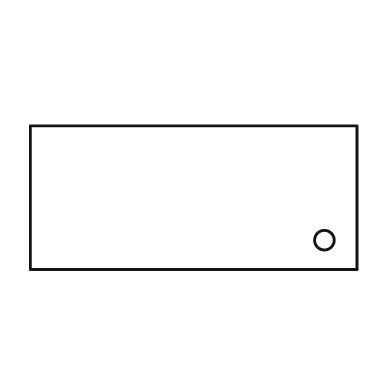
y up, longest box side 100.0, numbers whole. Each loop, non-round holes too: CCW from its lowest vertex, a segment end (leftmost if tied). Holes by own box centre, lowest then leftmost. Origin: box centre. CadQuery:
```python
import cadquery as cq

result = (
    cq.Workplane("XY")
    .moveTo(-50.0, -22.0)
    .lineTo(50.0, -22.0)
    .lineTo(50.0, 22.0)
    .lineTo(-50.0, 22.0)
    .close()
    .moveTo(40.0, -13.0)
    .circle(3.0)
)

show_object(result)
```